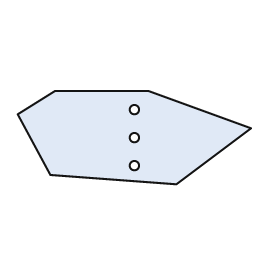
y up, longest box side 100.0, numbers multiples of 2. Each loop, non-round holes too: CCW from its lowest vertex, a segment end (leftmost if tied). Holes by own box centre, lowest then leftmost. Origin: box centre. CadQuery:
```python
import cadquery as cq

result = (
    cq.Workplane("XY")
    .moveTo(18.0, -20.0)
    .lineTo(50.0, 4.0)
    .lineTo(6.0, 20.0)
    .lineTo(-34.0, 20.0)
    .lineTo(-50.0, 10.0)
    .lineTo(-36.0, -16.0)
    .close()
    .moveTo(0.0, -12.0)
    .circle(2.0)
    .moveTo(0.0, 0.0)
    .circle(2.0)
    .moveTo(0.0, 12.0)
    .circle(2.0)
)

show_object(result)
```